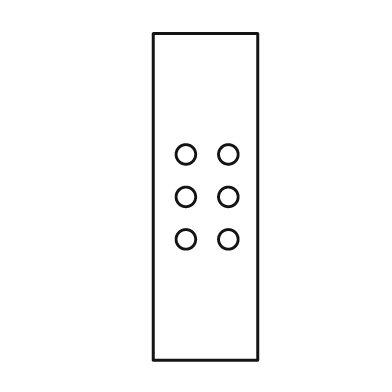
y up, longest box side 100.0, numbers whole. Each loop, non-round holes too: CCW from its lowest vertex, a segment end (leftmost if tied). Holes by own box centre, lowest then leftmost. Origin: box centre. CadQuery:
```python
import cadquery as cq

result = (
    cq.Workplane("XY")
    .moveTo(-16.0, -50.0)
    .lineTo(16.0, -50.0)
    .lineTo(16.0, 50.0)
    .lineTo(-16.0, 50.0)
    .close()
    .moveTo(-6.0, -13.0)
    .circle(3.0)
    .moveTo(7.0, -13.0)
    .circle(3.0)
    .moveTo(-6.0, 0.0)
    .circle(3.0)
    .moveTo(7.0, 0.0)
    .circle(3.0)
    .moveTo(-6.0, 13.0)
    .circle(3.0)
    .moveTo(7.0, 13.0)
    .circle(3.0)
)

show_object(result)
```